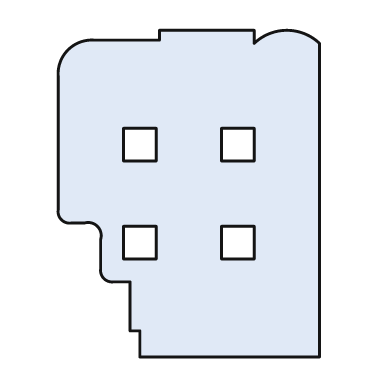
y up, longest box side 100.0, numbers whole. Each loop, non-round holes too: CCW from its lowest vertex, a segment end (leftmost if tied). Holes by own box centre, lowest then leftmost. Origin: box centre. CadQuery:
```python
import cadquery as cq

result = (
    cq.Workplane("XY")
    .moveTo(-15.0, -50.0)
    .lineTo(40.0, -50.0)
    .lineTo(40.0, 46.0)
    .threePointArc((30.0, 50.0), (20.0, 46.0))
    .lineTo(20.0, 50.0)
    .lineTo(-9.0, 50.0)
    .lineTo(-9.0, 47.0)
    .lineTo(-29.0, 47.0)
    .threePointArc((-37.0, 44.0), (-40.0, 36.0))
    .lineTo(-40.0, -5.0)
    .threePointArc((-39.0, -8.0), (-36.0, -9.0))
    .lineTo(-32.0, -9.0)
    .threePointArc((-28.0, -10.0), (-27.0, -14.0))
    .lineTo(-27.0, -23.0)
    .threePointArc((-26.0, -26.0), (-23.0, -27.0))
    .lineTo(-18.0, -27.0)
    .lineTo(-18.0, -42.0)
    .lineTo(-15.0, -42.0)
    .close()
    .moveTo(-20.0, -20.0)
    .lineTo(-10.0, -20.0)
    .lineTo(-10.0, -10.0)
    .lineTo(-20.0, -10.0)
    .close()
    .moveTo(10.0, -20.0)
    .lineTo(20.0, -20.0)
    .lineTo(20.0, -10.0)
    .lineTo(10.0, -10.0)
    .close()
    .moveTo(-20.0, 10.0)
    .lineTo(-10.0, 10.0)
    .lineTo(-10.0, 20.0)
    .lineTo(-20.0, 20.0)
    .close()
    .moveTo(10.0, 10.0)
    .lineTo(20.0, 10.0)
    .lineTo(20.0, 20.0)
    .lineTo(10.0, 20.0)
    .close()
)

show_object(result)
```